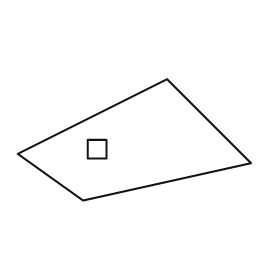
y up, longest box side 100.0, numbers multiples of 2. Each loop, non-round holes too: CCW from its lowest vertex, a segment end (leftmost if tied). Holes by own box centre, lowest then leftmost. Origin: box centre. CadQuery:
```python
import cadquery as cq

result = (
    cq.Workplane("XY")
    .moveTo(-22.0, -26.0)
    .lineTo(50.0, -10.0)
    .lineTo(14.0, 26.0)
    .lineTo(-50.0, -6.0)
    .close()
    .moveTo(-20.0, -8.0)
    .lineTo(-12.0, -8.0)
    .lineTo(-12.0, 0.0)
    .lineTo(-20.0, 0.0)
    .close()
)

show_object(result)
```